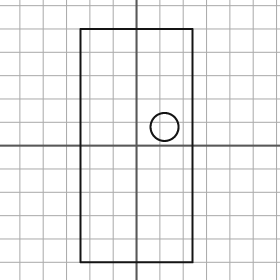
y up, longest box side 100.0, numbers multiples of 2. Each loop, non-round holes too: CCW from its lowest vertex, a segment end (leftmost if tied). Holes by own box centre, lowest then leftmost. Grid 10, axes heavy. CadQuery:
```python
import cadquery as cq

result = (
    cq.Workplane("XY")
    .moveTo(-24.0, -50.0)
    .lineTo(24.0, -50.0)
    .lineTo(24.0, 50.0)
    .lineTo(-24.0, 50.0)
    .close()
    .moveTo(12.0, 8.0)
    .circle(6.0)
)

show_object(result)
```